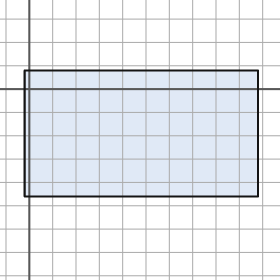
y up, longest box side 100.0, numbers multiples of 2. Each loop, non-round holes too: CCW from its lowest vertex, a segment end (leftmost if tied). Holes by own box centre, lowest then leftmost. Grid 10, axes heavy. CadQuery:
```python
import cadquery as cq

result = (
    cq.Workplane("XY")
    .moveTo(-2.0, -46.0)
    .lineTo(98.0, -46.0)
    .lineTo(98.0, 8.0)
    .lineTo(-2.0, 8.0)
    .close()
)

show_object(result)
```